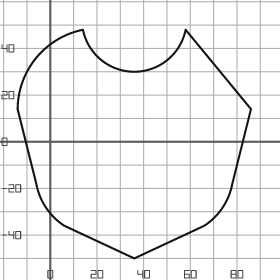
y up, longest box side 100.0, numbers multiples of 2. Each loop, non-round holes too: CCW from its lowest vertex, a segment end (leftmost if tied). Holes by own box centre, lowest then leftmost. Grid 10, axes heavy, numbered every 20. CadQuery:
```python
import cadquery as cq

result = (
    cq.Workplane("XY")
    .moveTo(36.0, -50.0)
    .lineTo(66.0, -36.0)
    .threePointArc((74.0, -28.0), (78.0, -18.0))
    .lineTo(86.0, 14.0)
    .lineTo(58.0, 48.0)
    .threePointArc((36.0, 30.0), (14.0, 48.0))
    .threePointArc((-6.0, 36.0), (-14.0, 14.0))
    .lineTo(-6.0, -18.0)
    .threePointArc((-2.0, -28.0), (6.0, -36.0))
    .close()
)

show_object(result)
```